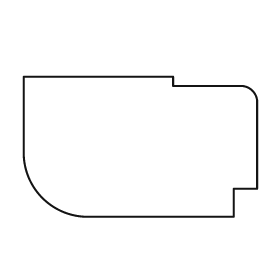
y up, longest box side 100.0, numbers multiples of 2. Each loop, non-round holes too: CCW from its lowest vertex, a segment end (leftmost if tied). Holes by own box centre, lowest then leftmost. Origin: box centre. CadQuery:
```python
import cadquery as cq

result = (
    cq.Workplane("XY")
    .moveTo(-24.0, -30.0)
    .lineTo(40.0, -30.0)
    .lineTo(40.0, -18.0)
    .lineTo(50.0, -18.0)
    .lineTo(50.0, 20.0)
    .threePointArc((48.0, 24.0), (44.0, 26.0))
    .lineTo(14.0, 26.0)
    .lineTo(14.0, 30.0)
    .lineTo(-50.0, 30.0)
    .lineTo(-50.0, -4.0)
    .threePointArc((-42.0, -22.0), (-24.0, -30.0))
    .close()
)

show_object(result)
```